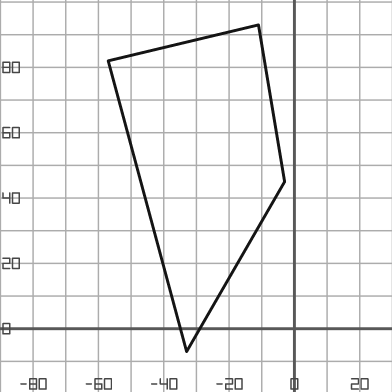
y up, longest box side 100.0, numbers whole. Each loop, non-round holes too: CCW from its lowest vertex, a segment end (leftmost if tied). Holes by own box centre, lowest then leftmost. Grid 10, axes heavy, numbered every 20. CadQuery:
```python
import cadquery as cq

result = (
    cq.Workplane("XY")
    .moveTo(-33.0, -7.0)
    .lineTo(-3.0, 45.0)
    .lineTo(-11.0, 93.0)
    .lineTo(-57.0, 82.0)
    .close()
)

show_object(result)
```